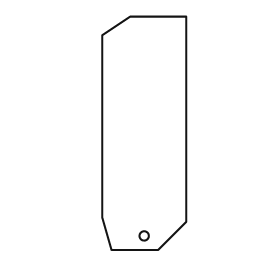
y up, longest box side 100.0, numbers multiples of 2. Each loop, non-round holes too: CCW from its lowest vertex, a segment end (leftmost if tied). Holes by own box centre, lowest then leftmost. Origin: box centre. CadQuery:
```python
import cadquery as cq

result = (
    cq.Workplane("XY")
    .moveTo(-14.0, -50.0)
    .lineTo(6.0, -50.0)
    .lineTo(18.0, -38.0)
    .lineTo(18.0, 50.0)
    .lineTo(-6.0, 50.0)
    .lineTo(-18.0, 42.0)
    .lineTo(-18.0, -36.0)
    .close()
    .moveTo(0.0, -44.0)
    .circle(2.0)
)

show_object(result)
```